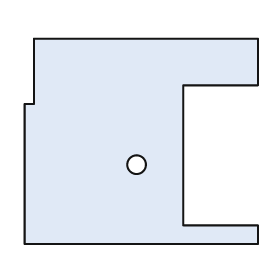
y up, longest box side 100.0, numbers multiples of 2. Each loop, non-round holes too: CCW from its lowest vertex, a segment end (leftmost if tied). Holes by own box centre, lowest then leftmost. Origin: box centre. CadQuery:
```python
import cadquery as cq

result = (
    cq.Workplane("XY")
    .moveTo(-50.0, -44.0)
    .lineTo(50.0, -44.0)
    .lineTo(50.0, -36.0)
    .lineTo(18.0, -36.0)
    .lineTo(18.0, 24.0)
    .lineTo(50.0, 24.0)
    .lineTo(50.0, 44.0)
    .lineTo(-46.0, 44.0)
    .lineTo(-46.0, 16.0)
    .lineTo(-50.0, 16.0)
    .close()
    .moveTo(-2.0, -10.0)
    .circle(4.0)
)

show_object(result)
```